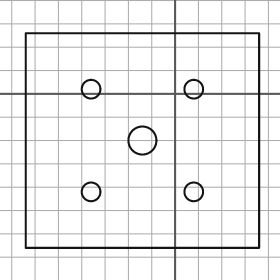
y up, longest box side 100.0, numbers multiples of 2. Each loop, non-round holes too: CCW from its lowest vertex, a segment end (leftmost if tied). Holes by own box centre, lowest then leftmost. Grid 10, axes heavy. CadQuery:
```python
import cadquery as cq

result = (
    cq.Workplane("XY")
    .moveTo(-64.0, -66.0)
    .lineTo(36.0, -66.0)
    .lineTo(36.0, 26.0)
    .lineTo(-64.0, 26.0)
    .close()
    .moveTo(-36.0, -42.0)
    .circle(4.0)
    .moveTo(8.0, -42.0)
    .circle(4.0)
    .moveTo(-14.0, -20.0)
    .circle(6.0)
    .moveTo(-36.0, 2.0)
    .circle(4.0)
    .moveTo(8.0, 2.0)
    .circle(4.0)
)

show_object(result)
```